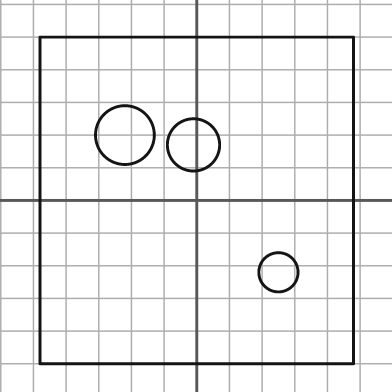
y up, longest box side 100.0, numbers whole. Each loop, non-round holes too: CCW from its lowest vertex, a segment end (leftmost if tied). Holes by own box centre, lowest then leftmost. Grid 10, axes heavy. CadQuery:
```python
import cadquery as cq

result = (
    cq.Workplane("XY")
    .moveTo(-48.0, -50.0)
    .lineTo(48.0, -50.0)
    .lineTo(48.0, 50.0)
    .lineTo(-48.0, 50.0)
    .close()
    .moveTo(25.0, -22.0)
    .circle(6.0)
    .moveTo(-1.0, 17.0)
    .circle(8.0)
    .moveTo(-22.0, 20.0)
    .circle(9.0)
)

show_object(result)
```